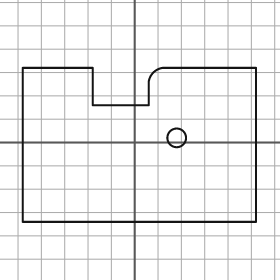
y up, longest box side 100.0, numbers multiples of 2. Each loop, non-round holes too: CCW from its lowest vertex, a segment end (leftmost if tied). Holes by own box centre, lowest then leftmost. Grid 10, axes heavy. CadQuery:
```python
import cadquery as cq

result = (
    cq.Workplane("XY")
    .moveTo(-48.0, -34.0)
    .lineTo(52.0, -34.0)
    .lineTo(52.0, 32.0)
    .lineTo(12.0, 32.0)
    .threePointArc((8.0, 30.0), (6.0, 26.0))
    .lineTo(6.0, 16.0)
    .lineTo(-18.0, 16.0)
    .lineTo(-18.0, 32.0)
    .lineTo(-48.0, 32.0)
    .close()
    .moveTo(18.0, 2.0)
    .circle(4.0)
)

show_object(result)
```